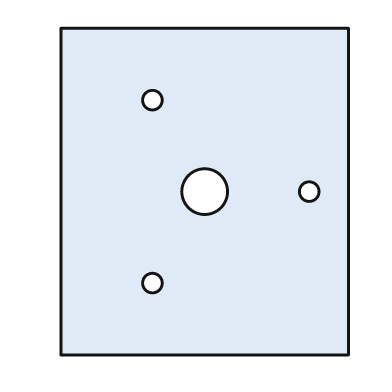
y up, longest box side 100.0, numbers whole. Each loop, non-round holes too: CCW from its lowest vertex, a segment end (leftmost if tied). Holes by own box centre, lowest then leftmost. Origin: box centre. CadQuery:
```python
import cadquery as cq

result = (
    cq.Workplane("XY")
    .moveTo(-44.0, -50.0)
    .lineTo(44.0, -50.0)
    .lineTo(44.0, 50.0)
    .lineTo(-44.0, 50.0)
    .close()
    .moveTo(-16.0, -28.0)
    .circle(3.0)
    .moveTo(0.0, 0.0)
    .circle(7.0)
    .moveTo(32.0, 0.0)
    .circle(3.0)
    .moveTo(-16.0, 28.0)
    .circle(3.0)
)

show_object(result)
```